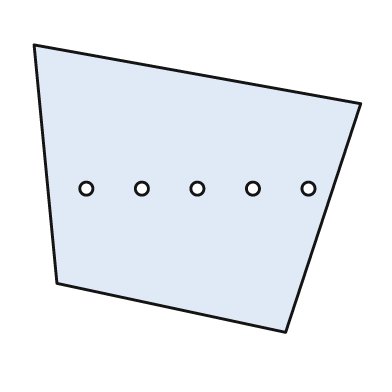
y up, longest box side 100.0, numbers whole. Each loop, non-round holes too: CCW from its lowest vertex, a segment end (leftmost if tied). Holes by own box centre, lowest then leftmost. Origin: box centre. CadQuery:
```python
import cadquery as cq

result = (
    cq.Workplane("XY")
    .moveTo(27.0, -44.0)
    .lineTo(50.0, 26.0)
    .lineTo(-50.0, 44.0)
    .lineTo(-43.0, -29.0)
    .close()
    .moveTo(-34.0, 0.0)
    .circle(2.0)
    .moveTo(-17.0, 0.0)
    .circle(2.0)
    .moveTo(0.0, 0.0)
    .circle(2.0)
    .moveTo(17.0, 0.0)
    .circle(2.0)
    .moveTo(34.0, 0.0)
    .circle(2.0)
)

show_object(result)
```